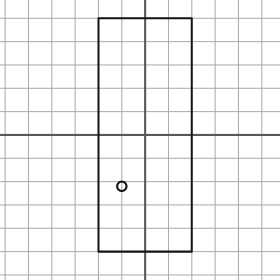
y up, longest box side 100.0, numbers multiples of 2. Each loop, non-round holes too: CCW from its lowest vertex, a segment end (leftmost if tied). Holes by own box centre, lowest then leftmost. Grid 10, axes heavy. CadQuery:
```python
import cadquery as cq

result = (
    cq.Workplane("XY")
    .moveTo(-20.0, -50.0)
    .lineTo(20.0, -50.0)
    .lineTo(20.0, 50.0)
    .lineTo(-20.0, 50.0)
    .close()
    .moveTo(-10.0, -22.0)
    .circle(2.0)
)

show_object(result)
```